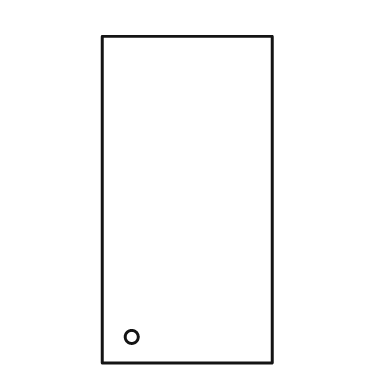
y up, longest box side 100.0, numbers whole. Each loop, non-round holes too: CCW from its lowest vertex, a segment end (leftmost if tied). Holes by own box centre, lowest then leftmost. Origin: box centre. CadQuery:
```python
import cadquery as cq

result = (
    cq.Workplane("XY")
    .moveTo(-26.0, -50.0)
    .lineTo(26.0, -50.0)
    .lineTo(26.0, 50.0)
    .lineTo(-26.0, 50.0)
    .close()
    .moveTo(-17.0, -42.0)
    .circle(2.0)
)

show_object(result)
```